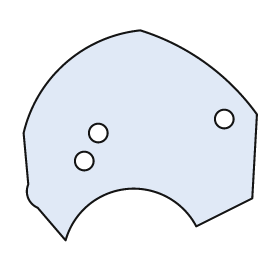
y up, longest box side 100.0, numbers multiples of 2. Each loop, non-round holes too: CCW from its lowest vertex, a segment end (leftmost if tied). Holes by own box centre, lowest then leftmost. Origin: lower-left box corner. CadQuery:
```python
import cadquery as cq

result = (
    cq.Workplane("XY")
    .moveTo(18.0, 0.0)
    .threePointArc((44.0, 22.0), (74.0, 6.0))
    .lineTo(98.0, 18.0)
    .lineTo(100.0, 54.0)
    .threePointArc((78.0, 76.0), (50.0, 90.0))
    .threePointArc((18.0, 76.0), (0.0, 46.0))
    .lineTo(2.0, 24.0)
    .threePointArc((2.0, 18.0), (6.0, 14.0))
    .close()
    .moveTo(26.0, 34.0)
    .circle(4.0)
    .moveTo(32.0, 46.0)
    .circle(4.0)
    .moveTo(86.0, 52.0)
    .circle(4.0)
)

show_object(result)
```